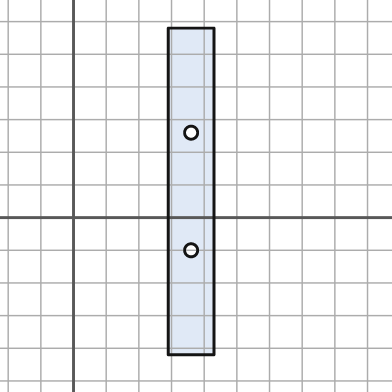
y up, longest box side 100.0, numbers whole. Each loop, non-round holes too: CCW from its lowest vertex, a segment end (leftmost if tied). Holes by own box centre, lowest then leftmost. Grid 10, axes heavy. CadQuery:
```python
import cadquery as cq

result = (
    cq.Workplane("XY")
    .moveTo(29.0, -42.0)
    .lineTo(43.0, -42.0)
    .lineTo(43.0, 58.0)
    .lineTo(29.0, 58.0)
    .close()
    .moveTo(36.0, -10.0)
    .circle(2.0)
    .moveTo(36.0, 26.0)
    .circle(2.0)
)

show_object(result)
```